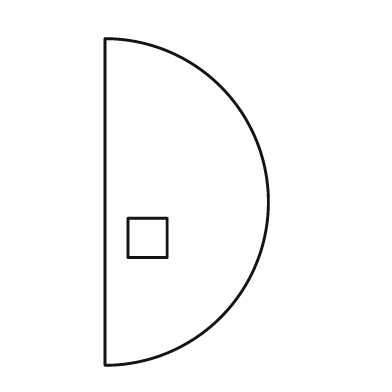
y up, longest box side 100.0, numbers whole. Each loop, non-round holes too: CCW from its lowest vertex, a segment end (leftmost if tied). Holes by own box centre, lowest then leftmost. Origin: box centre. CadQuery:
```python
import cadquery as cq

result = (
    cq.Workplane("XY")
    .moveTo(-25.0, -50.0)
    .threePointArc((25.0, 0.0), (-25.0, 50.0))
    .close()
    .moveTo(-18.0, -17.0)
    .lineTo(-6.0, -17.0)
    .lineTo(-6.0, -5.0)
    .lineTo(-18.0, -5.0)
    .close()
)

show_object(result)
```